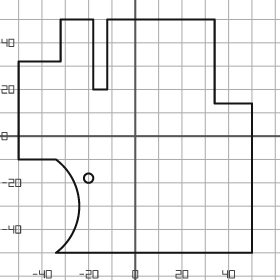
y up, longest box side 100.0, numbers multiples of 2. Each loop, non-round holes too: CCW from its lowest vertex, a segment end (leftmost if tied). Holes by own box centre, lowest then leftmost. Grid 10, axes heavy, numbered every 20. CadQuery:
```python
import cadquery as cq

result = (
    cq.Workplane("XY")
    .moveTo(-34.0, -50.0)
    .lineTo(50.0, -50.0)
    .lineTo(50.0, 14.0)
    .lineTo(34.0, 14.0)
    .lineTo(34.0, 50.0)
    .lineTo(-12.0, 50.0)
    .lineTo(-12.0, 20.0)
    .lineTo(-18.0, 20.0)
    .lineTo(-18.0, 50.0)
    .lineTo(-32.0, 50.0)
    .lineTo(-32.0, 32.0)
    .lineTo(-50.0, 32.0)
    .lineTo(-50.0, -10.0)
    .lineTo(-34.0, -10.0)
    .threePointArc((-24.0, -30.0), (-34.0, -50.0))
    .close()
    .moveTo(-20.0, -18.0)
    .circle(2.0)
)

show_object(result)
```